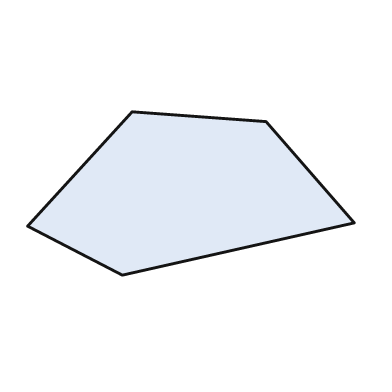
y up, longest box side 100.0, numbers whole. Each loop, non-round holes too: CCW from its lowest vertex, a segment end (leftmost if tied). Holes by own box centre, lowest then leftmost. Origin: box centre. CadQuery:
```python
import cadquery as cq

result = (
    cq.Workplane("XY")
    .moveTo(-21.0, -25.0)
    .lineTo(50.0, -9.0)
    .lineTo(23.0, 22.0)
    .lineTo(-18.0, 25.0)
    .lineTo(-50.0, -10.0)
    .close()
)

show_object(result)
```